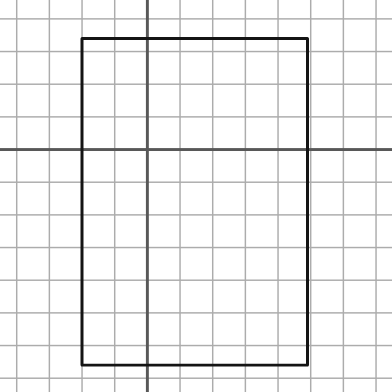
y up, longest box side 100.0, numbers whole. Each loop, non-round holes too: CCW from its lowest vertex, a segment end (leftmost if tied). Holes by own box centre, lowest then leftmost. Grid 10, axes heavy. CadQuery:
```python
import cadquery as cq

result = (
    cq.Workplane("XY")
    .moveTo(-20.0, -66.0)
    .lineTo(49.0, -66.0)
    .lineTo(49.0, 34.0)
    .lineTo(-20.0, 34.0)
    .close()
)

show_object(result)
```